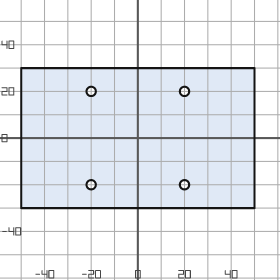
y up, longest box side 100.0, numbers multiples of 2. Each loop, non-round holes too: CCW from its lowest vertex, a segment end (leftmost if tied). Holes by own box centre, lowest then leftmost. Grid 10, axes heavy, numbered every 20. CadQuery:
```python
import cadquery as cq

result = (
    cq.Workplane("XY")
    .moveTo(-50.0, -30.0)
    .lineTo(50.0, -30.0)
    .lineTo(50.0, 30.0)
    .lineTo(-50.0, 30.0)
    .close()
    .moveTo(-20.0, -20.0)
    .circle(2.0)
    .moveTo(20.0, -20.0)
    .circle(2.0)
    .moveTo(-20.0, 20.0)
    .circle(2.0)
    .moveTo(20.0, 20.0)
    .circle(2.0)
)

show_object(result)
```